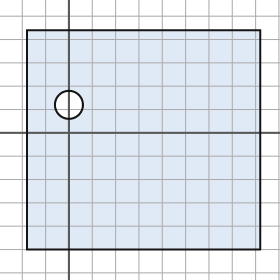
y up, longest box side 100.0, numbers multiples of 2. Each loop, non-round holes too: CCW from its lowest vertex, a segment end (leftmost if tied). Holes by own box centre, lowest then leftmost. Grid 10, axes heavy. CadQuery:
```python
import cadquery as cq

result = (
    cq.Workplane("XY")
    .moveTo(-18.0, -50.0)
    .lineTo(82.0, -50.0)
    .lineTo(82.0, 44.0)
    .lineTo(-18.0, 44.0)
    .close()
    .moveTo(0.0, 12.0)
    .circle(6.0)
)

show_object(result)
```